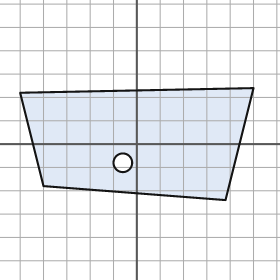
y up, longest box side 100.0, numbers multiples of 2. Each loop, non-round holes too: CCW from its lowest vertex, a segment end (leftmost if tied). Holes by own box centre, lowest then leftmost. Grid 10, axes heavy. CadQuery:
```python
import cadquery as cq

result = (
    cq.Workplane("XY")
    .moveTo(38.0, -24.0)
    .lineTo(50.0, 24.0)
    .lineTo(-50.0, 22.0)
    .lineTo(-40.0, -18.0)
    .close()
    .moveTo(-6.0, -8.0)
    .circle(4.0)
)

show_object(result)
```